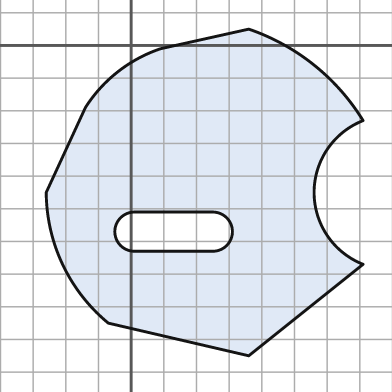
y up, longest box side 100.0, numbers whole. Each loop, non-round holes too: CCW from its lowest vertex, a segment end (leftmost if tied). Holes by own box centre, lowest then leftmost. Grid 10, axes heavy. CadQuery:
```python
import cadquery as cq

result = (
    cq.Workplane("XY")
    .moveTo(36.0, -95.0)
    .lineTo(71.0, -67.0)
    .threePointArc((56.0, -45.0), (71.0, -23.0))
    .threePointArc((56.0, -6.0), (36.0, 5.0))
    .lineTo(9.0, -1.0)
    .threePointArc((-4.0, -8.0), (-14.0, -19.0))
    .lineTo(-26.0, -45.0)
    .threePointArc((-21.0, -67.0), (-7.0, -85.0))
    .close()
    .moveTo(1.0, -63.0)
    .lineTo(25.0, -63.0)
    .threePointArc((31.0, -57.0), (25.0, -51.0))
    .lineTo(1.0, -51.0)
    .threePointArc((-5.0, -57.0), (1.0, -63.0))
    .close()
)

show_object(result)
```